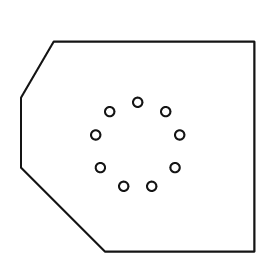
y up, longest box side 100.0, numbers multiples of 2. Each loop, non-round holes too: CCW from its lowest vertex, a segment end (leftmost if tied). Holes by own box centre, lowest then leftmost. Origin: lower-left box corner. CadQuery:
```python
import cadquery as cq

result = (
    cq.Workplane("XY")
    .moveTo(36.0, 0.0)
    .lineTo(100.0, 0.0)
    .lineTo(100.0, 90.0)
    .lineTo(14.0, 90.0)
    .lineTo(0.0, 66.0)
    .lineTo(0.0, 36.0)
    .close()
    .moveTo(44.0, 28.0)
    .circle(2.0)
    .moveTo(56.0, 28.0)
    .circle(2.0)
    .moveTo(34.0, 36.0)
    .circle(2.0)
    .moveTo(66.0, 36.0)
    .circle(2.0)
    .moveTo(32.0, 50.0)
    .circle(2.0)
    .moveTo(68.0, 50.0)
    .circle(2.0)
    .moveTo(38.0, 60.0)
    .circle(2.0)
    .moveTo(62.0, 60.0)
    .circle(2.0)
    .moveTo(50.0, 64.0)
    .circle(2.0)
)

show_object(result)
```